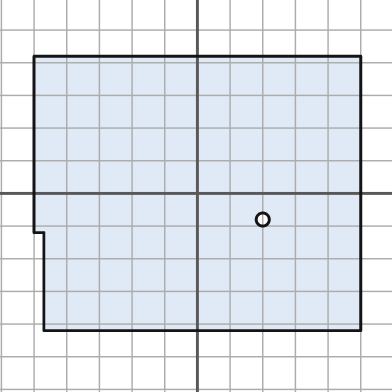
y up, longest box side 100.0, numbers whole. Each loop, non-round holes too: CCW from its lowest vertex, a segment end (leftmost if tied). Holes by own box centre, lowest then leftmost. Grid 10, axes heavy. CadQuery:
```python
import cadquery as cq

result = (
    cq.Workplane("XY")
    .moveTo(-47.0, -42.0)
    .lineTo(50.0, -42.0)
    .lineTo(50.0, 42.0)
    .lineTo(-50.0, 42.0)
    .lineTo(-50.0, -12.0)
    .lineTo(-47.0, -12.0)
    .close()
    .moveTo(20.0, -8.0)
    .circle(2.0)
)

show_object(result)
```